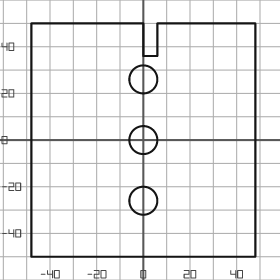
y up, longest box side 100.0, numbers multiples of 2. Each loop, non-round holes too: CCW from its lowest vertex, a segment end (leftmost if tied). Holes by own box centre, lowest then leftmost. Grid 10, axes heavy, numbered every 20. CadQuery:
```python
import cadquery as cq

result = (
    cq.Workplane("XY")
    .moveTo(-48.0, -50.0)
    .lineTo(48.0, -50.0)
    .lineTo(48.0, 50.0)
    .lineTo(6.0, 50.0)
    .lineTo(6.0, 36.0)
    .lineTo(0.0, 36.0)
    .lineTo(0.0, 50.0)
    .lineTo(-48.0, 50.0)
    .close()
    .moveTo(0.0, -26.0)
    .circle(6.0)
    .moveTo(0.0, 0.0)
    .circle(6.0)
    .moveTo(0.0, 26.0)
    .circle(6.0)
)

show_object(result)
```